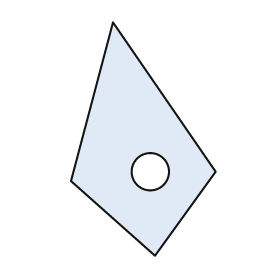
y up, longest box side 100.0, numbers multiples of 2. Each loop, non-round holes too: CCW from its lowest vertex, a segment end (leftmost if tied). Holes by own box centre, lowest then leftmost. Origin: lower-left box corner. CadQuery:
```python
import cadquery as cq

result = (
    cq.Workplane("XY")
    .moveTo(36.0, 0.0)
    .lineTo(62.0, 36.0)
    .lineTo(18.0, 100.0)
    .lineTo(0.0, 32.0)
    .close()
    .moveTo(34.0, 36.0)
    .circle(8.0)
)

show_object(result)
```